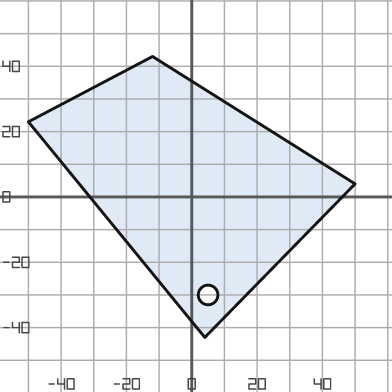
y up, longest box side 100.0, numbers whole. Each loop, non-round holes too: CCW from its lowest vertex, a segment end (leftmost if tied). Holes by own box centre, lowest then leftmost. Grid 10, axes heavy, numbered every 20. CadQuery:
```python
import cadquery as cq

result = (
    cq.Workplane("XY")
    .moveTo(4.0, -43.0)
    .lineTo(50.0, 4.0)
    .lineTo(-12.0, 43.0)
    .lineTo(-50.0, 23.0)
    .close()
    .moveTo(5.0, -30.0)
    .circle(3.0)
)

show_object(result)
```